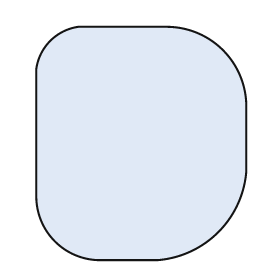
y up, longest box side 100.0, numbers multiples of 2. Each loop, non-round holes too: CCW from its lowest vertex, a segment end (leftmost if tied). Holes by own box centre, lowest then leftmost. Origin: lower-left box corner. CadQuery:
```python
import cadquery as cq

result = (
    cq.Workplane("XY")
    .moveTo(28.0, 0.0)
    .lineTo(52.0, 0.0)
    .threePointArc((78.0, 12.0), (90.0, 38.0))
    .lineTo(90.0, 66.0)
    .threePointArc((80.0, 90.0), (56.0, 100.0))
    .lineTo(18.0, 100.0)
    .threePointArc((6.0, 94.0), (0.0, 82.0))
    .lineTo(0.0, 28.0)
    .threePointArc((8.0, 8.0), (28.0, 0.0))
    .close()
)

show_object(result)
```